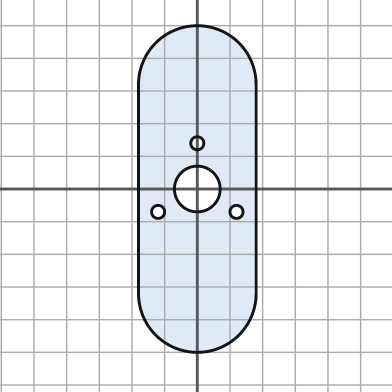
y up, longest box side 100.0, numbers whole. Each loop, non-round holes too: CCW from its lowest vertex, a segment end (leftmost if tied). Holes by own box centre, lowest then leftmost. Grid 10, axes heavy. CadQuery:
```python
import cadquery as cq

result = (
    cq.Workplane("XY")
    .moveTo(-18.0, -32.0)
    .threePointArc((0.0, -50.0), (18.0, -32.0))
    .lineTo(18.0, 32.0)
    .threePointArc((0.0, 50.0), (-18.0, 32.0))
    .close()
    .moveTo(-12.0, -7.0)
    .circle(2.0)
    .moveTo(12.0, -7.0)
    .circle(2.0)
    .moveTo(0.0, 0.0)
    .circle(7.0)
    .moveTo(0.0, 14.0)
    .circle(2.0)
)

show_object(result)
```